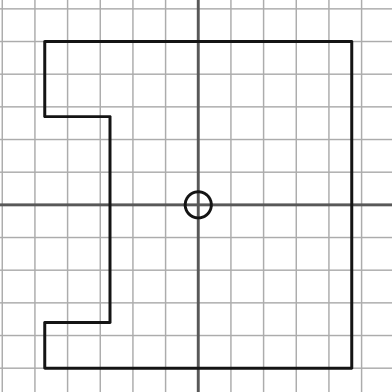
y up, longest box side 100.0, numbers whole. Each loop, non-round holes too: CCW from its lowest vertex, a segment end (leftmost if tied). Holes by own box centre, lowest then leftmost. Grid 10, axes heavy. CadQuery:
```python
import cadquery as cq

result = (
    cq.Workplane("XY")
    .moveTo(-47.0, -50.0)
    .lineTo(47.0, -50.0)
    .lineTo(47.0, 50.0)
    .lineTo(-47.0, 50.0)
    .lineTo(-47.0, 27.0)
    .lineTo(-27.0, 27.0)
    .lineTo(-27.0, -36.0)
    .lineTo(-47.0, -36.0)
    .close()
    .moveTo(0.0, 0.0)
    .circle(4.0)
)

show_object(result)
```